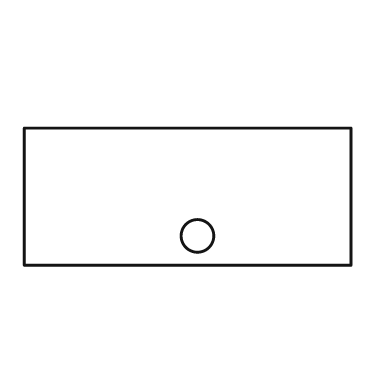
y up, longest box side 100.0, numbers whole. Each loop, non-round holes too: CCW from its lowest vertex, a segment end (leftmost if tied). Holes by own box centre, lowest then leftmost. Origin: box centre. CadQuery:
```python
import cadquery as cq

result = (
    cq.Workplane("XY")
    .moveTo(-50.0, -21.0)
    .lineTo(50.0, -21.0)
    .lineTo(50.0, 21.0)
    .lineTo(-50.0, 21.0)
    .close()
    .moveTo(3.0, -12.0)
    .circle(5.0)
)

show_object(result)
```